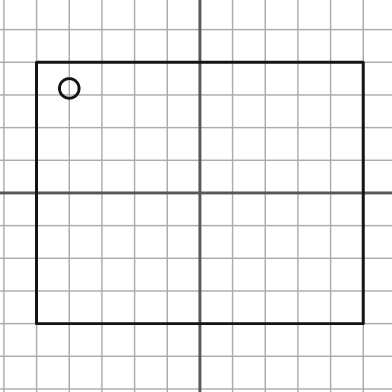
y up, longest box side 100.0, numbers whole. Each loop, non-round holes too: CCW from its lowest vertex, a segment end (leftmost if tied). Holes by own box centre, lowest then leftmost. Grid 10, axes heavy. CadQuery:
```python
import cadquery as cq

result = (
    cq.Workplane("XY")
    .moveTo(-50.0, -40.0)
    .lineTo(50.0, -40.0)
    .lineTo(50.0, 40.0)
    .lineTo(-50.0, 40.0)
    .close()
    .moveTo(-40.0, 32.0)
    .circle(3.0)
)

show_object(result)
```